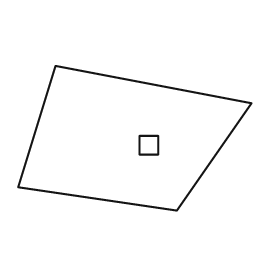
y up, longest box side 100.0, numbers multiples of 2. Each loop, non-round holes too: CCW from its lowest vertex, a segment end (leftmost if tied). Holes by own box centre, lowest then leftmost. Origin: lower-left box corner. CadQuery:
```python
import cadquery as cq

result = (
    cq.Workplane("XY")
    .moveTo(68.0, 0.0)
    .lineTo(100.0, 46.0)
    .lineTo(16.0, 62.0)
    .lineTo(0.0, 10.0)
    .close()
    .moveTo(52.0, 24.0)
    .lineTo(60.0, 24.0)
    .lineTo(60.0, 32.0)
    .lineTo(52.0, 32.0)
    .close()
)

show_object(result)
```